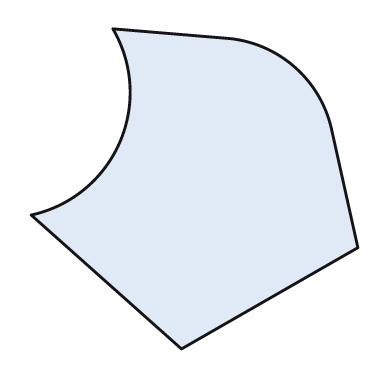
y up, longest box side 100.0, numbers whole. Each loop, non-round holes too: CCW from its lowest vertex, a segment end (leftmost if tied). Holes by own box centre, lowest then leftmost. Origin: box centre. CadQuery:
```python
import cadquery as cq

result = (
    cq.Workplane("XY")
    .moveTo(-4.0, -49.0)
    .lineTo(50.0, -18.0)
    .lineTo(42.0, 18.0)
    .threePointArc((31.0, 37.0), (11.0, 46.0))
    .lineTo(-25.0, 49.0)
    .threePointArc((-23.0, 14.0), (-50.0, -8.0))
    .close()
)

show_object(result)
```